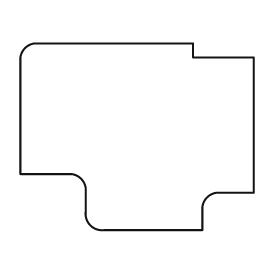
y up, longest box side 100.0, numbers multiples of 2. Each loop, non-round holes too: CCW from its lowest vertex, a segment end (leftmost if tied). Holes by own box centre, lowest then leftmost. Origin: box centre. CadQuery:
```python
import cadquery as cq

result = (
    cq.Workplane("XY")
    .moveTo(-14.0, -40.0)
    .lineTo(28.0, -40.0)
    .lineTo(28.0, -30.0)
    .threePointArc((30.0, -26.0), (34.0, -24.0))
    .lineTo(50.0, -24.0)
    .lineTo(50.0, 34.0)
    .lineTo(24.0, 34.0)
    .lineTo(24.0, 40.0)
    .lineTo(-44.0, 40.0)
    .threePointArc((-48.0, 38.0), (-50.0, 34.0))
    .lineTo(-50.0, -16.0)
    .lineTo(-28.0, -16.0)
    .threePointArc((-24.0, -18.0), (-22.0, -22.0))
    .lineTo(-22.0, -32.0)
    .threePointArc((-20.0, -38.0), (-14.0, -40.0))
    .close()
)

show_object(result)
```